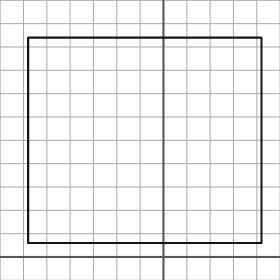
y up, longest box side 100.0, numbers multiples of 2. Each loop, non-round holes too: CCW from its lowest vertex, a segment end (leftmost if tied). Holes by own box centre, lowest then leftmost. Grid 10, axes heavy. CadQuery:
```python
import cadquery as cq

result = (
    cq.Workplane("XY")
    .moveTo(-58.0, 6.0)
    .lineTo(42.0, 6.0)
    .lineTo(42.0, 94.0)
    .lineTo(-58.0, 94.0)
    .close()
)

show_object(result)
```